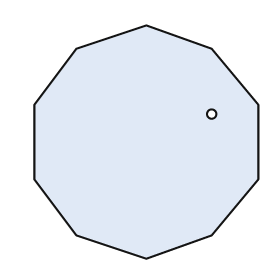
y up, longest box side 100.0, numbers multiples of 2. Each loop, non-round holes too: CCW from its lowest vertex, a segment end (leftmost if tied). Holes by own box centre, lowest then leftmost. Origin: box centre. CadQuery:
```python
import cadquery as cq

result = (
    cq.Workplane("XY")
    .moveTo(0.0, -50.0)
    .lineTo(28.0, -40.0)
    .lineTo(48.0, -16.0)
    .lineTo(48.0, 16.0)
    .lineTo(28.0, 40.0)
    .lineTo(0.0, 50.0)
    .lineTo(-30.0, 40.0)
    .lineTo(-48.0, 16.0)
    .lineTo(-48.0, -16.0)
    .lineTo(-30.0, -40.0)
    .close()
    .moveTo(28.0, 12.0)
    .circle(2.0)
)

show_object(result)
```